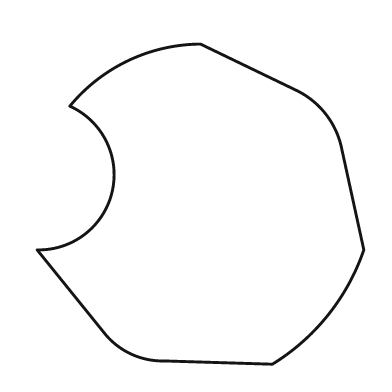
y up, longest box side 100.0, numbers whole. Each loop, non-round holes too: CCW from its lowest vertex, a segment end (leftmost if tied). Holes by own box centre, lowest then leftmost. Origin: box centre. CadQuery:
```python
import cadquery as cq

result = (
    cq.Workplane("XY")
    .moveTo(22.0, -49.0)
    .threePointArc((39.0, -34.0), (50.0, -14.0))
    .lineTo(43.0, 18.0)
    .threePointArc((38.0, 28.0), (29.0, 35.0))
    .lineTo(0.0, 49.0)
    .threePointArc((-22.0, 44.0), (-40.0, 30.0))
    .threePointArc((-27.0, 4.0), (-50.0, -14.0))
    .lineTo(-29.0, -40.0)
    .threePointArc((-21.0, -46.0), (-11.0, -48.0))
    .close()
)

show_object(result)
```